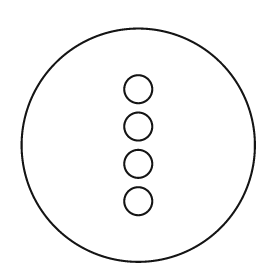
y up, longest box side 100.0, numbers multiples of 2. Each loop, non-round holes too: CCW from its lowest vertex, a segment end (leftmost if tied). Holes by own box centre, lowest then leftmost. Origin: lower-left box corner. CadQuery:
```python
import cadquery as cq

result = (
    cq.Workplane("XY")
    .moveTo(50.0, 50.0)
    .circle(50.0)
    .moveTo(50.0, 26.0)
    .circle(6.0)
    .moveTo(50.0, 42.0)
    .circle(6.0)
    .moveTo(50.0, 58.0)
    .circle(6.0)
    .moveTo(50.0, 74.0)
    .circle(6.0)
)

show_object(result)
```